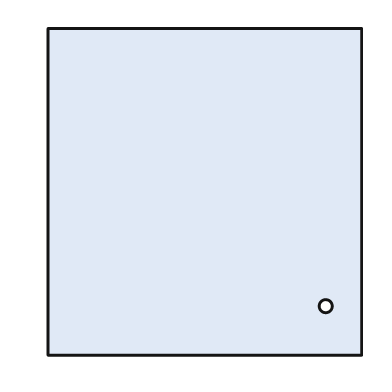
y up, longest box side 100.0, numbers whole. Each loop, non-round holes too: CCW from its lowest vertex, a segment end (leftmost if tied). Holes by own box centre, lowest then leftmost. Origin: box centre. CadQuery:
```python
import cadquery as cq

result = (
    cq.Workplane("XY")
    .moveTo(-48.0, -50.0)
    .lineTo(48.0, -50.0)
    .lineTo(48.0, 50.0)
    .lineTo(-48.0, 50.0)
    .close()
    .moveTo(37.0, -35.0)
    .circle(2.0)
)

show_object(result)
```